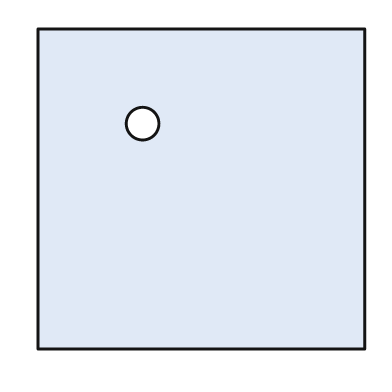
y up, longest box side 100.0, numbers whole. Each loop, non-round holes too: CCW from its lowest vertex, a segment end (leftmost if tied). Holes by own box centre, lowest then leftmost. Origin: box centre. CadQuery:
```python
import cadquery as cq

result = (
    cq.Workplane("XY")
    .moveTo(-50.0, -49.0)
    .lineTo(50.0, -49.0)
    .lineTo(50.0, 49.0)
    .lineTo(-50.0, 49.0)
    .close()
    .moveTo(-18.0, 20.0)
    .circle(5.0)
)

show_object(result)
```